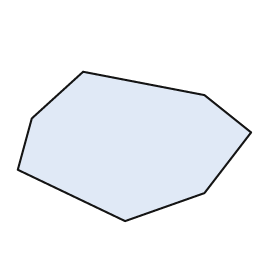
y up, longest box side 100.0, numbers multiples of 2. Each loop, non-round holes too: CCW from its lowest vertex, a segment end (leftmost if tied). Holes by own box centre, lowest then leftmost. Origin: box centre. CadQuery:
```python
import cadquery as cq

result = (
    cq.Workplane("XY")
    .moveTo(-4.0, -32.0)
    .lineTo(30.0, -20.0)
    .lineTo(50.0, 6.0)
    .lineTo(30.0, 22.0)
    .lineTo(-22.0, 32.0)
    .lineTo(-44.0, 12.0)
    .lineTo(-50.0, -10.0)
    .close()
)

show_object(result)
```